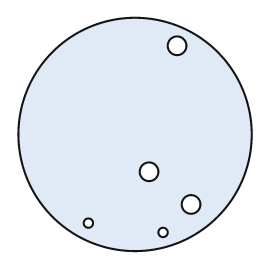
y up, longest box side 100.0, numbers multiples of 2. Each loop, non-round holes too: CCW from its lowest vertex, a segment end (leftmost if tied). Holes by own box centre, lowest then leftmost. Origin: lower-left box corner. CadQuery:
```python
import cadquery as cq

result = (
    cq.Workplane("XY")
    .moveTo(50.0, 50.0)
    .circle(50.0)
    .moveTo(62.0, 8.0)
    .circle(2.0)
    .moveTo(30.0, 12.0)
    .circle(2.0)
    .moveTo(74.0, 20.0)
    .circle(4.0)
    .moveTo(56.0, 34.0)
    .circle(4.0)
    .moveTo(68.0, 88.0)
    .circle(4.0)
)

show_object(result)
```